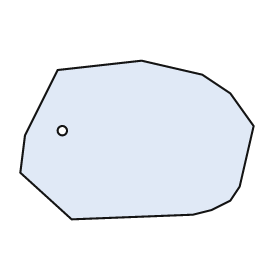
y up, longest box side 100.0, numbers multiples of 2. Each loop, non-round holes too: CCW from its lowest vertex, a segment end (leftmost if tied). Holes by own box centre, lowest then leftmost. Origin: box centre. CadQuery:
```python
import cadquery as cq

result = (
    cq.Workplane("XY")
    .moveTo(-28.0, -34.0)
    .lineTo(24.0, -32.0)
    .lineTo(32.0, -30.0)
    .lineTo(40.0, -26.0)
    .lineTo(44.0, -20.0)
    .lineTo(50.0, 6.0)
    .lineTo(40.0, 20.0)
    .lineTo(28.0, 28.0)
    .lineTo(2.0, 34.0)
    .lineTo(-34.0, 30.0)
    .lineTo(-48.0, 2.0)
    .lineTo(-50.0, -14.0)
    .close()
    .moveTo(-32.0, 4.0)
    .circle(2.0)
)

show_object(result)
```